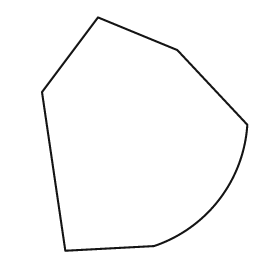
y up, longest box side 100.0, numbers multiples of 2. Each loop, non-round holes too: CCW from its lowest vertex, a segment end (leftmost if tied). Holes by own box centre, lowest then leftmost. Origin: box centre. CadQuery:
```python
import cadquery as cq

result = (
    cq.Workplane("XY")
    .moveTo(-34.0, -50.0)
    .lineTo(4.0, -48.0)
    .threePointArc((32.0, -28.0), (44.0, 4.0))
    .lineTo(14.0, 36.0)
    .lineTo(-20.0, 50.0)
    .lineTo(-44.0, 18.0)
    .close()
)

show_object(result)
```